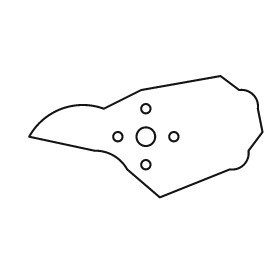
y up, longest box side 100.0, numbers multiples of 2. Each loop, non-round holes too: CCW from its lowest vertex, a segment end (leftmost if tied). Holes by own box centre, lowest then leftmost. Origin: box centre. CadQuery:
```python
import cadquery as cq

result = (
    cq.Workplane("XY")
    .moveTo(6.0, -26.0)
    .lineTo(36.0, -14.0)
    .threePointArc((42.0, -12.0), (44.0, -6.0))
    .lineTo(50.0, 2.0)
    .lineTo(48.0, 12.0)
    .threePointArc((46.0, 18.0), (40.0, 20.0))
    .lineTo(32.0, 26.0)
    .lineTo(-2.0, 20.0)
    .lineTo(-18.0, 12.0)
    .threePointArc((-36.0, 12.0), (-50.0, 0.0))
    .lineTo(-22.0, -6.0)
    .threePointArc((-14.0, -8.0), (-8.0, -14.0))
    .close()
    .moveTo(0.0, -12.0)
    .circle(2.0)
    .moveTo(-12.0, 0.0)
    .circle(2.0)
    .moveTo(0.0, 0.0)
    .circle(4.0)
    .moveTo(12.0, 0.0)
    .circle(2.0)
    .moveTo(0.0, 12.0)
    .circle(2.0)
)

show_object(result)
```